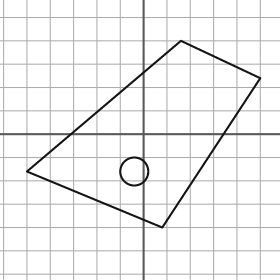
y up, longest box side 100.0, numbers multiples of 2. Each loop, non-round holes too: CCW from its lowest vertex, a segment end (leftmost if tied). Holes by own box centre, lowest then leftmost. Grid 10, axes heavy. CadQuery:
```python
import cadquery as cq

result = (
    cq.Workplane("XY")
    .moveTo(8.0, -40.0)
    .lineTo(50.0, 24.0)
    .lineTo(16.0, 40.0)
    .lineTo(-50.0, -16.0)
    .close()
    .moveTo(-4.0, -16.0)
    .circle(6.0)
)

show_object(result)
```